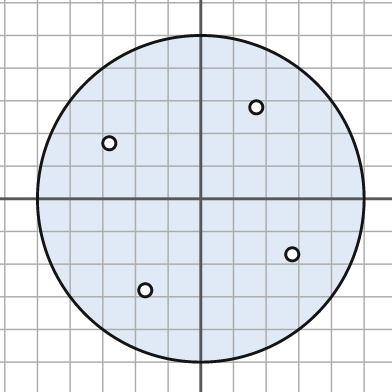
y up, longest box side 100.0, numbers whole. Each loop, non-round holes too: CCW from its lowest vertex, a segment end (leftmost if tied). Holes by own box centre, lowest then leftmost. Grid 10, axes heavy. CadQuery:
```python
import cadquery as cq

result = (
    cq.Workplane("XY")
    .moveTo(0.0, 0.0)
    .circle(50.0)
    .moveTo(-17.0, -28.0)
    .circle(2.0)
    .moveTo(28.0, -17.0)
    .circle(2.0)
    .moveTo(-28.0, 17.0)
    .circle(2.0)
    .moveTo(17.0, 28.0)
    .circle(2.0)
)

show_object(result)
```